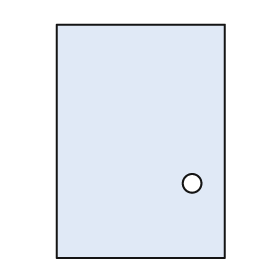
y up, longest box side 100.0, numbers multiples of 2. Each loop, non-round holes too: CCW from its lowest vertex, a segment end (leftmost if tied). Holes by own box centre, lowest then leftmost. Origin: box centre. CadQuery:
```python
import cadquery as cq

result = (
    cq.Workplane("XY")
    .moveTo(-36.0, -50.0)
    .lineTo(36.0, -50.0)
    .lineTo(36.0, 50.0)
    .lineTo(-36.0, 50.0)
    .close()
    .moveTo(22.0, -18.0)
    .circle(4.0)
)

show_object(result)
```